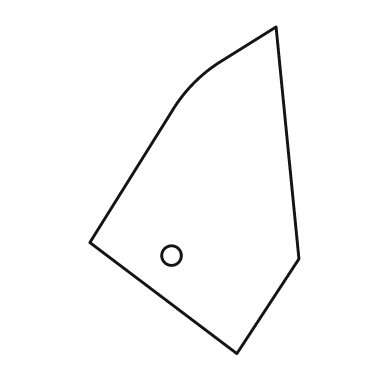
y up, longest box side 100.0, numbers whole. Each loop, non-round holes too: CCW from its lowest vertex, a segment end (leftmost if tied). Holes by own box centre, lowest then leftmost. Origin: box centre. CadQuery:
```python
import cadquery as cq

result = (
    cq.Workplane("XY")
    .moveTo(13.0, -50.0)
    .lineTo(32.0, -21.0)
    .lineTo(25.0, 50.0)
    .lineTo(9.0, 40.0)
    .threePointArc((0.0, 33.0), (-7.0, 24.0))
    .lineTo(-32.0, -16.0)
    .close()
    .moveTo(-7.0, -20.0)
    .circle(3.0)
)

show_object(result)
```